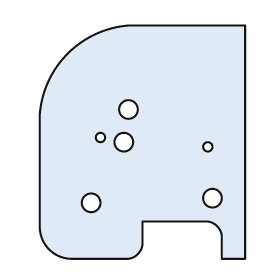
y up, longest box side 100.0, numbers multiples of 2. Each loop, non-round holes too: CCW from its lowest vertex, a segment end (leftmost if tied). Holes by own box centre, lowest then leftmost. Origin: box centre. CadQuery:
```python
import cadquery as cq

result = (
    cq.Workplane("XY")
    .moveTo(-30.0, -50.0)
    .lineTo(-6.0, -50.0)
    .threePointArc((-2.0, -48.0), (0.0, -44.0))
    .lineTo(0.0, -34.0)
    .lineTo(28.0, -34.0)
    .threePointArc((32.0, -36.0), (34.0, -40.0))
    .lineTo(34.0, -50.0)
    .lineTo(44.0, -50.0)
    .lineTo(44.0, 50.0)
    .lineTo(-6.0, 50.0)
    .threePointArc((-32.0, 38.0), (-44.0, 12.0))
    .lineTo(-44.0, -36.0)
    .threePointArc((-40.0, -46.0), (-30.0, -50.0))
    .close()
    .moveTo(-22.0, -26.0)
    .circle(4.0)
    .moveTo(30.0, -24.0)
    .circle(4.0)
    .moveTo(28.0, -2.0)
    .circle(2.0)
    .moveTo(-8.0, 0.0)
    .circle(4.0)
    .moveTo(-18.0, 2.0)
    .circle(2.0)
    .moveTo(-6.0, 14.0)
    .circle(4.0)
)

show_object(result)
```